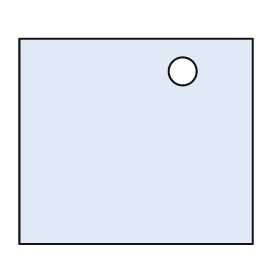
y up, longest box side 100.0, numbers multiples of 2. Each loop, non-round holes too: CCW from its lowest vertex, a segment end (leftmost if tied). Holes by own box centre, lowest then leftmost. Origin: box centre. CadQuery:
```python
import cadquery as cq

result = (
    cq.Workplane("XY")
    .moveTo(-50.0, -44.0)
    .lineTo(50.0, -44.0)
    .lineTo(50.0, 44.0)
    .lineTo(-50.0, 44.0)
    .close()
    .moveTo(20.0, 30.0)
    .circle(6.0)
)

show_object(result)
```